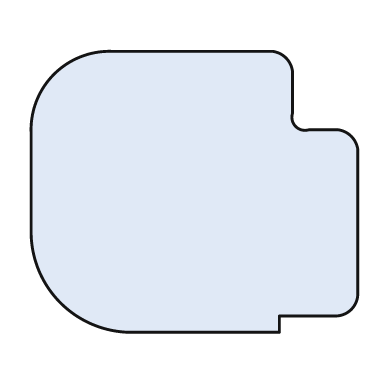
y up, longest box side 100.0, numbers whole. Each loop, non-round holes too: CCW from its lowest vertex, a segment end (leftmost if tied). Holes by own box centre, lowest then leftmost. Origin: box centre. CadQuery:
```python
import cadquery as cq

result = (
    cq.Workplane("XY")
    .moveTo(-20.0, -43.0)
    .lineTo(26.0, -43.0)
    .lineTo(26.0, -38.0)
    .lineTo(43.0, -38.0)
    .threePointArc((48.0, -36.0), (50.0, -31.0))
    .lineTo(50.0, 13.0)
    .threePointArc((48.0, 17.0), (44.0, 19.0))
    .lineTo(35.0, 19.0)
    .threePointArc((31.0, 20.0), (30.0, 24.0))
    .lineTo(30.0, 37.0)
    .threePointArc((28.0, 41.0), (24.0, 43.0))
    .lineTo(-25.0, 43.0)
    .threePointArc((-43.0, 36.0), (-50.0, 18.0))
    .lineTo(-50.0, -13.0)
    .threePointArc((-41.0, -34.0), (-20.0, -43.0))
    .close()
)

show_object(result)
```